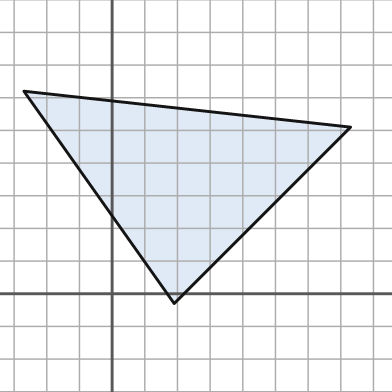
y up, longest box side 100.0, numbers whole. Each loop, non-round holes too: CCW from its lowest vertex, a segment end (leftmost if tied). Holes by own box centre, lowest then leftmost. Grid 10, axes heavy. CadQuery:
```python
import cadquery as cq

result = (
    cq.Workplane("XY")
    .moveTo(19.0, -3.0)
    .lineTo(73.0, 51.0)
    .lineTo(-27.0, 62.0)
    .close()
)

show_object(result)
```